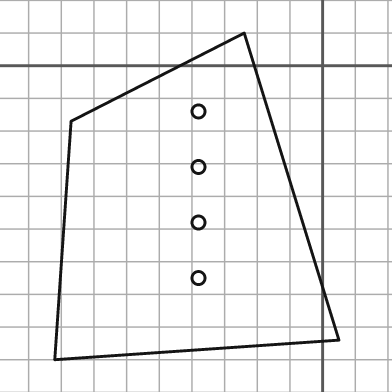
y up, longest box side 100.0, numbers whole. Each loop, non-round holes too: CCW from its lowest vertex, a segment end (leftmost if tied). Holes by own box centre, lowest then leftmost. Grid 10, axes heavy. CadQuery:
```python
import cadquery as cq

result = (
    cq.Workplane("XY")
    .moveTo(-82.0, -90.0)
    .lineTo(5.0, -84.0)
    .lineTo(-24.0, 10.0)
    .lineTo(-77.0, -17.0)
    .close()
    .moveTo(-38.0, -65.0)
    .circle(2.0)
    .moveTo(-38.0, -48.0)
    .circle(2.0)
    .moveTo(-38.0, -31.0)
    .circle(2.0)
    .moveTo(-38.0, -14.0)
    .circle(2.0)
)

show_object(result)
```